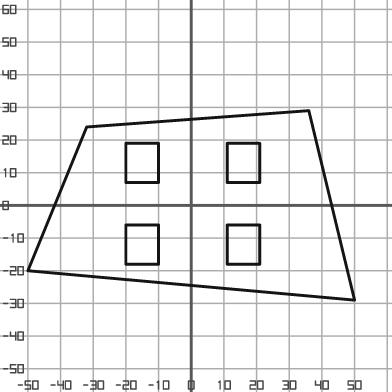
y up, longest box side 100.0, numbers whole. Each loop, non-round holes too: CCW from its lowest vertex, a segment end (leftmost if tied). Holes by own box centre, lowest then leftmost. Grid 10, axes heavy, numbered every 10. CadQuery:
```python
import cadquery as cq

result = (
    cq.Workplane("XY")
    .moveTo(50.0, -29.0)
    .lineTo(36.0, 29.0)
    .lineTo(-32.0, 24.0)
    .lineTo(-50.0, -20.0)
    .close()
    .moveTo(-20.0, -18.0)
    .lineTo(-10.0, -18.0)
    .lineTo(-10.0, -6.0)
    .lineTo(-20.0, -6.0)
    .close()
    .moveTo(11.0, -18.0)
    .lineTo(21.0, -18.0)
    .lineTo(21.0, -6.0)
    .lineTo(11.0, -6.0)
    .close()
    .moveTo(-20.0, 7.0)
    .lineTo(-10.0, 7.0)
    .lineTo(-10.0, 19.0)
    .lineTo(-20.0, 19.0)
    .close()
    .moveTo(11.0, 7.0)
    .lineTo(21.0, 7.0)
    .lineTo(21.0, 19.0)
    .lineTo(11.0, 19.0)
    .close()
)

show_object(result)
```